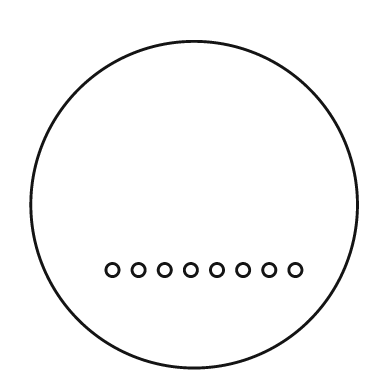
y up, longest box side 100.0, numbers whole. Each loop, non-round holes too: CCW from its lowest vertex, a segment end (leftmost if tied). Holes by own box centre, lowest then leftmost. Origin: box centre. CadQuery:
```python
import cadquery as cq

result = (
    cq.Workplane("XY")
    .moveTo(0.0, 0.0)
    .circle(50.0)
    .moveTo(-25.0, -20.0)
    .circle(2.0)
    .moveTo(-17.0, -20.0)
    .circle(2.0)
    .moveTo(-9.0, -20.0)
    .circle(2.0)
    .moveTo(-1.0, -20.0)
    .circle(2.0)
    .moveTo(7.0, -20.0)
    .circle(2.0)
    .moveTo(15.0, -20.0)
    .circle(2.0)
    .moveTo(23.0, -20.0)
    .circle(2.0)
    .moveTo(31.0, -20.0)
    .circle(2.0)
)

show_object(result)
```